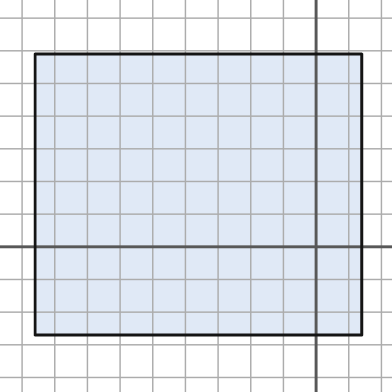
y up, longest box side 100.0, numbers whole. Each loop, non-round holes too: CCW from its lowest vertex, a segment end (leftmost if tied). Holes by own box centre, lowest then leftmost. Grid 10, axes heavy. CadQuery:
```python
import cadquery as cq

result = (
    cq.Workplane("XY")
    .moveTo(-86.0, -27.0)
    .lineTo(14.0, -27.0)
    .lineTo(14.0, 59.0)
    .lineTo(-86.0, 59.0)
    .close()
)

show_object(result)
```